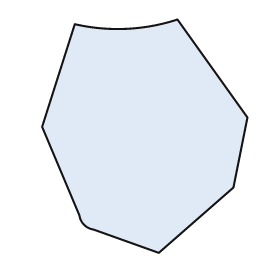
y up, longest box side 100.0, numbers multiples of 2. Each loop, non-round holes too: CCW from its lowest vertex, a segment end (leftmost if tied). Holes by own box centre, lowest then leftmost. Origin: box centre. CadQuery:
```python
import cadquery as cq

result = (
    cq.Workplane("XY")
    .moveTo(6.0, -50.0)
    .lineTo(38.0, -22.0)
    .lineTo(44.0, 8.0)
    .lineTo(14.0, 50.0)
    .threePointArc((-8.0, 46.0), (-30.0, 48.0))
    .lineTo(-44.0, 4.0)
    .lineTo(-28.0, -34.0)
    .threePointArc((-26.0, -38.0), (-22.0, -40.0))
    .close()
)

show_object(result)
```